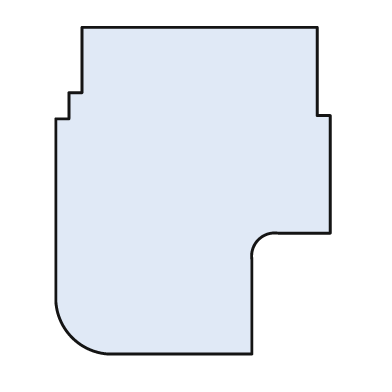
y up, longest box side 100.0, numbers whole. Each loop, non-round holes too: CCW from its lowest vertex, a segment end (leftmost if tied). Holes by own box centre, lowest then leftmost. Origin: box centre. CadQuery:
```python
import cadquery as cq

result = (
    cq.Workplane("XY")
    .moveTo(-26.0, -50.0)
    .lineTo(18.0, -50.0)
    .lineTo(18.0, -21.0)
    .threePointArc((20.0, -15.0), (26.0, -13.0))
    .lineTo(42.0, -13.0)
    .lineTo(42.0, 23.0)
    .lineTo(38.0, 23.0)
    .lineTo(38.0, 50.0)
    .lineTo(-34.0, 50.0)
    .lineTo(-34.0, 30.0)
    .lineTo(-38.0, 30.0)
    .lineTo(-38.0, 22.0)
    .lineTo(-42.0, 22.0)
    .lineTo(-42.0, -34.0)
    .threePointArc((-37.0, -45.0), (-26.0, -50.0))
    .close()
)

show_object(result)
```